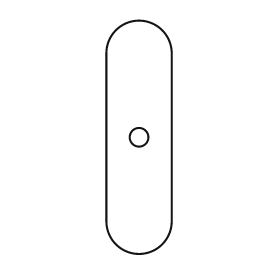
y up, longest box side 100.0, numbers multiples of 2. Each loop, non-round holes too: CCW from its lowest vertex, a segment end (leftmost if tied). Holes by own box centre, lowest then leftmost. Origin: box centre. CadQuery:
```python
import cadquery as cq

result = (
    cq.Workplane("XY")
    .moveTo(-14.0, -36.0)
    .threePointArc((0.0, -50.0), (14.0, -36.0))
    .lineTo(14.0, 36.0)
    .threePointArc((0.0, 50.0), (-14.0, 36.0))
    .close()
    .moveTo(0.0, 0.0)
    .circle(4.0)
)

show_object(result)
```